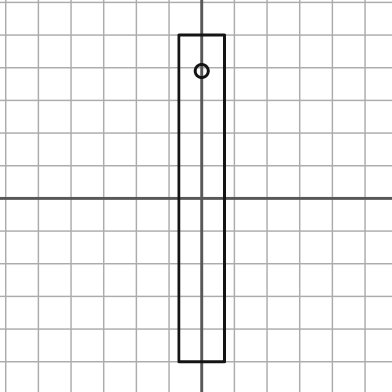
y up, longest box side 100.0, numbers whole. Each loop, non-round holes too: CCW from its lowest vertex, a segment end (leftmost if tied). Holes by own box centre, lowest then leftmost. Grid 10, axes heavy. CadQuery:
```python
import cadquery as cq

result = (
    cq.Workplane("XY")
    .moveTo(-7.0, -50.0)
    .lineTo(7.0, -50.0)
    .lineTo(7.0, 50.0)
    .lineTo(-7.0, 50.0)
    .close()
    .moveTo(0.0, 39.0)
    .circle(2.0)
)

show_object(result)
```